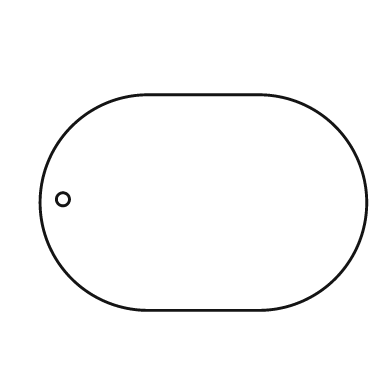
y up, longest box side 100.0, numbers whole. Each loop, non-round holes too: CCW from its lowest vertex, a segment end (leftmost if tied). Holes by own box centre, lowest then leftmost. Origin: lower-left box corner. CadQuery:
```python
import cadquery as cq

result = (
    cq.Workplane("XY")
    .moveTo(33.0, 0.0)
    .lineTo(67.0, 0.0)
    .threePointArc((100.0, 33.0), (67.0, 66.0))
    .lineTo(33.0, 66.0)
    .threePointArc((0.0, 33.0), (33.0, 0.0))
    .close()
    .moveTo(7.0, 34.0)
    .circle(2.0)
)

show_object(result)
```